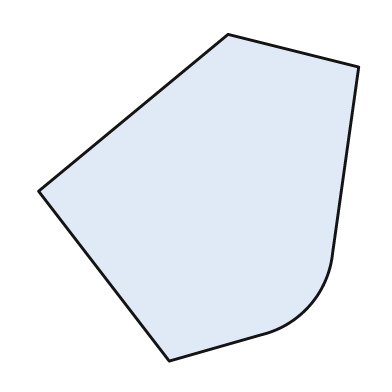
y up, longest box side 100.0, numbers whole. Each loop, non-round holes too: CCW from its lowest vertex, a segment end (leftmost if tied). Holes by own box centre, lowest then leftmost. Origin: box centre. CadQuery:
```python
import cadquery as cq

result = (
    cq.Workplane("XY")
    .moveTo(-9.0, -50.0)
    .lineTo(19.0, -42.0)
    .threePointArc((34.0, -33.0), (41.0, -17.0))
    .lineTo(49.0, 40.0)
    .lineTo(9.0, 50.0)
    .lineTo(-49.0, 2.0)
    .close()
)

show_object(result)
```